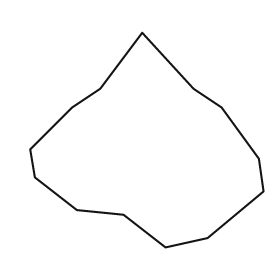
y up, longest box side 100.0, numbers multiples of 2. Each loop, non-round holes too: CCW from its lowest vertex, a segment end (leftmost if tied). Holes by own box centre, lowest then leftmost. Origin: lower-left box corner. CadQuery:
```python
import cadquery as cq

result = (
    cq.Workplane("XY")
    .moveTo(58.0, 0.0)
    .lineTo(76.0, 4.0)
    .lineTo(100.0, 24.0)
    .lineTo(98.0, 38.0)
    .lineTo(82.0, 60.0)
    .lineTo(70.0, 68.0)
    .lineTo(48.0, 92.0)
    .lineTo(30.0, 68.0)
    .lineTo(18.0, 60.0)
    .lineTo(0.0, 42.0)
    .lineTo(2.0, 30.0)
    .lineTo(20.0, 16.0)
    .lineTo(40.0, 14.0)
    .close()
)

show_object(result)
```